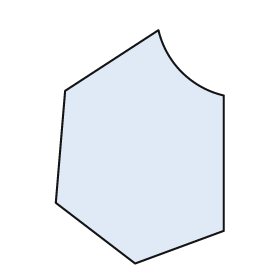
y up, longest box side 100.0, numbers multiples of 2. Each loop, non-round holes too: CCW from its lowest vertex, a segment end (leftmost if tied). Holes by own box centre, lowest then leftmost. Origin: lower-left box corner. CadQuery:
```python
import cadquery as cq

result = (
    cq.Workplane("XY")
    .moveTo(34.0, 0.0)
    .lineTo(72.0, 14.0)
    .lineTo(72.0, 72.0)
    .threePointArc((54.0, 82.0), (44.0, 100.0))
    .lineTo(4.0, 74.0)
    .lineTo(0.0, 26.0)
    .close()
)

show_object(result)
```